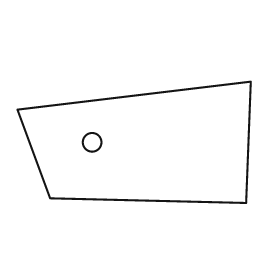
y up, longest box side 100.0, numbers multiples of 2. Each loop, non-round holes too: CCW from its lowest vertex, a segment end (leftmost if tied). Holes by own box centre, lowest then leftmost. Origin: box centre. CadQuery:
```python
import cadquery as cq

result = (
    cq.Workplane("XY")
    .moveTo(48.0, -26.0)
    .lineTo(50.0, 26.0)
    .lineTo(-50.0, 14.0)
    .lineTo(-36.0, -24.0)
    .close()
    .moveTo(-18.0, 0.0)
    .circle(4.0)
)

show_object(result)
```